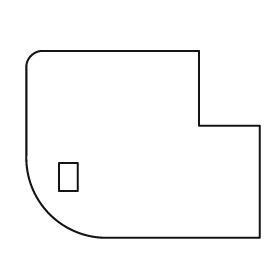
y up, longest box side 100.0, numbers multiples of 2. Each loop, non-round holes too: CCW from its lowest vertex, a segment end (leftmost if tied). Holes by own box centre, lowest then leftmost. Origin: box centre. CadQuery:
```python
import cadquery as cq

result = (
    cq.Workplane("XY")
    .moveTo(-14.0, -40.0)
    .lineTo(50.0, -40.0)
    .lineTo(50.0, 8.0)
    .lineTo(24.0, 8.0)
    .lineTo(24.0, 40.0)
    .lineTo(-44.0, 40.0)
    .threePointArc((-48.0, 38.0), (-50.0, 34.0))
    .lineTo(-50.0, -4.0)
    .threePointArc((-40.0, -30.0), (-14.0, -40.0))
    .close()
    .moveTo(-36.0, -20.0)
    .lineTo(-28.0, -20.0)
    .lineTo(-28.0, -8.0)
    .lineTo(-36.0, -8.0)
    .close()
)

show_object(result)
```